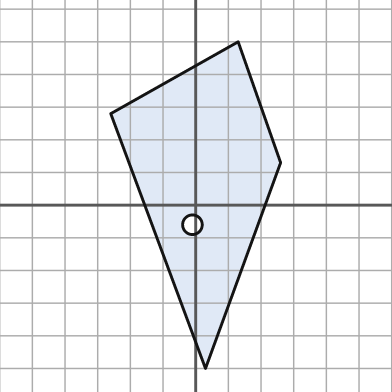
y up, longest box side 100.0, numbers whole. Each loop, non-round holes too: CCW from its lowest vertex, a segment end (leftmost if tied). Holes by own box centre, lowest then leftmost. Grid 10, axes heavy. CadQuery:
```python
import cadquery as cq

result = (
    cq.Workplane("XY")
    .moveTo(3.0, -50.0)
    .lineTo(26.0, 13.0)
    .lineTo(13.0, 50.0)
    .lineTo(-26.0, 28.0)
    .close()
    .moveTo(-1.0, -6.0)
    .circle(3.0)
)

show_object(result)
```